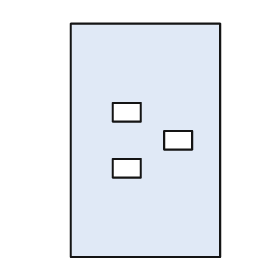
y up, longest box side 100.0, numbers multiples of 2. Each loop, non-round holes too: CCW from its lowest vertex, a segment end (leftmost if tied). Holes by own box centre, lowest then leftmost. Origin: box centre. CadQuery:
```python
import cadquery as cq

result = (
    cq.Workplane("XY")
    .moveTo(-32.0, -50.0)
    .lineTo(32.0, -50.0)
    .lineTo(32.0, 50.0)
    .lineTo(-32.0, 50.0)
    .close()
    .moveTo(-14.0, -16.0)
    .lineTo(-2.0, -16.0)
    .lineTo(-2.0, -8.0)
    .lineTo(-14.0, -8.0)
    .close()
    .moveTo(8.0, -4.0)
    .lineTo(20.0, -4.0)
    .lineTo(20.0, 4.0)
    .lineTo(8.0, 4.0)
    .close()
    .moveTo(-14.0, 8.0)
    .lineTo(-2.0, 8.0)
    .lineTo(-2.0, 16.0)
    .lineTo(-14.0, 16.0)
    .close()
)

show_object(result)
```